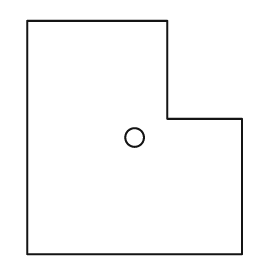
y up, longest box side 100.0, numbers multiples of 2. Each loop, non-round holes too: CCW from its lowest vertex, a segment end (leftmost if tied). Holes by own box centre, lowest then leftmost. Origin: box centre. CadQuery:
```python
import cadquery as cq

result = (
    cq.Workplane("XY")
    .moveTo(-46.0, -50.0)
    .lineTo(46.0, -50.0)
    .lineTo(46.0, 8.0)
    .lineTo(14.0, 8.0)
    .lineTo(14.0, 50.0)
    .lineTo(-46.0, 50.0)
    .close()
    .moveTo(0.0, 0.0)
    .circle(4.0)
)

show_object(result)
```